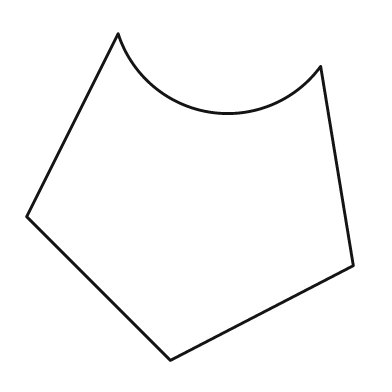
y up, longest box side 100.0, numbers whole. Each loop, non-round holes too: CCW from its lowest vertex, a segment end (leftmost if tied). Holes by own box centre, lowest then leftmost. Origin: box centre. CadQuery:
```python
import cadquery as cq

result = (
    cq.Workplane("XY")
    .moveTo(-6.0, -50.0)
    .lineTo(50.0, -21.0)
    .lineTo(40.0, 40.0)
    .threePointArc((6.0, 26.0), (-22.0, 50.0))
    .lineTo(-50.0, -6.0)
    .close()
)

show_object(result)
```